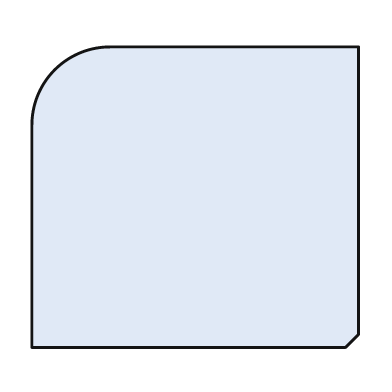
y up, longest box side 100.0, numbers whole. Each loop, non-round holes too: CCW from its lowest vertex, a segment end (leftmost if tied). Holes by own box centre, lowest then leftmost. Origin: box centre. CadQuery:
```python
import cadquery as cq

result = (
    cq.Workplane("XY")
    .moveTo(-50.0, -46.0)
    .lineTo(46.0, -46.0)
    .lineTo(50.0, -42.0)
    .lineTo(50.0, 46.0)
    .lineTo(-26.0, 46.0)
    .threePointArc((-43.0, 39.0), (-50.0, 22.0))
    .close()
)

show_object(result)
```